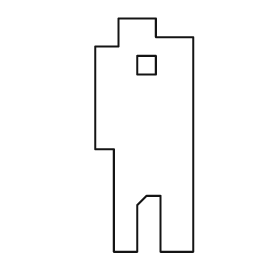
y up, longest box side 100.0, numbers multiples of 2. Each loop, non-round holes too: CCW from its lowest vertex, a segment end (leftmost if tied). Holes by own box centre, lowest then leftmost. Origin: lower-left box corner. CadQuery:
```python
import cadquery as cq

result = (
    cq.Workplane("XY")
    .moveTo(8.0, 0.0)
    .lineTo(18.0, 0.0)
    .lineTo(18.0, 20.0)
    .lineTo(22.0, 24.0)
    .lineTo(28.0, 24.0)
    .lineTo(28.0, 0.0)
    .lineTo(42.0, 0.0)
    .lineTo(42.0, 92.0)
    .lineTo(26.0, 92.0)
    .lineTo(26.0, 100.0)
    .lineTo(10.0, 100.0)
    .lineTo(10.0, 88.0)
    .lineTo(0.0, 88.0)
    .lineTo(0.0, 44.0)
    .lineTo(8.0, 44.0)
    .close()
    .moveTo(18.0, 76.0)
    .lineTo(26.0, 76.0)
    .lineTo(26.0, 84.0)
    .lineTo(18.0, 84.0)
    .close()
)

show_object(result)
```